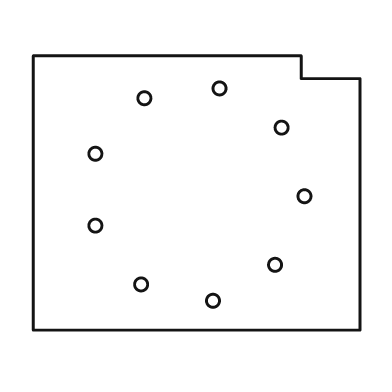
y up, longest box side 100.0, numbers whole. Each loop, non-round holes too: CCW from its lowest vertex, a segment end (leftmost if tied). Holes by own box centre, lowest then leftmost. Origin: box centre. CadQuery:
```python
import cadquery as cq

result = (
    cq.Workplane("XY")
    .moveTo(-50.0, -42.0)
    .lineTo(50.0, -42.0)
    .lineTo(50.0, 35.0)
    .lineTo(32.0, 35.0)
    .lineTo(32.0, 42.0)
    .lineTo(-50.0, 42.0)
    .close()
    .moveTo(5.0, -33.0)
    .circle(2.0)
    .moveTo(-17.0, -28.0)
    .circle(2.0)
    .moveTo(24.0, -22.0)
    .circle(2.0)
    .moveTo(-31.0, -10.0)
    .circle(2.0)
    .moveTo(33.0, -1.0)
    .circle(2.0)
    .moveTo(-31.0, 12.0)
    .circle(2.0)
    .moveTo(26.0, 20.0)
    .circle(2.0)
    .moveTo(-16.0, 29.0)
    .circle(2.0)
    .moveTo(7.0, 32.0)
    .circle(2.0)
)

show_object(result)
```